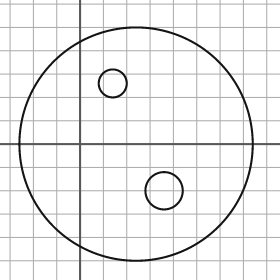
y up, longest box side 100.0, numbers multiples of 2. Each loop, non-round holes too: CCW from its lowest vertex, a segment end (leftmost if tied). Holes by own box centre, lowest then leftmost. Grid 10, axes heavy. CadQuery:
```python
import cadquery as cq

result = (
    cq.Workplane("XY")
    .moveTo(24.0, 0.0)
    .circle(50.0)
    .moveTo(36.0, -20.0)
    .circle(8.0)
    .moveTo(14.0, 26.0)
    .circle(6.0)
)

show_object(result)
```